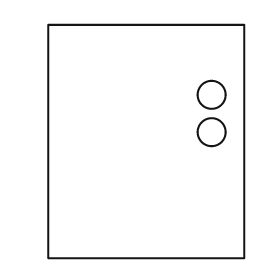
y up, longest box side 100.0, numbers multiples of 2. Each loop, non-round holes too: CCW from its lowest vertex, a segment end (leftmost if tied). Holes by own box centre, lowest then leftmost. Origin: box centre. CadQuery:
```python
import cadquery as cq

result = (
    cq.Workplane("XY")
    .moveTo(-42.0, -50.0)
    .lineTo(42.0, -50.0)
    .lineTo(42.0, 50.0)
    .lineTo(-42.0, 50.0)
    .close()
    .moveTo(28.0, 4.0)
    .circle(6.0)
    .moveTo(28.0, 20.0)
    .circle(6.0)
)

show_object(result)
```